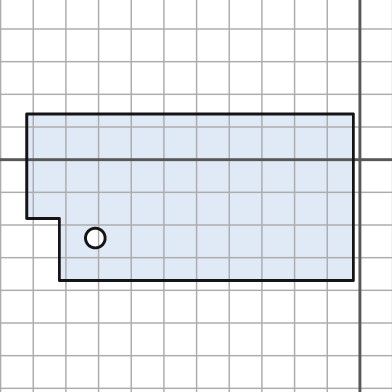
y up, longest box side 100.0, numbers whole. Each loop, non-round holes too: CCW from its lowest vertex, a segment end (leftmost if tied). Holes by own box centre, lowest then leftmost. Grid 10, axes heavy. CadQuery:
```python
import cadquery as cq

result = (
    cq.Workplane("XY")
    .moveTo(-92.0, -37.0)
    .lineTo(-2.0, -37.0)
    .lineTo(-2.0, 14.0)
    .lineTo(-102.0, 14.0)
    .lineTo(-102.0, -18.0)
    .lineTo(-92.0, -18.0)
    .close()
    .moveTo(-81.0, -24.0)
    .circle(3.0)
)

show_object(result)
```